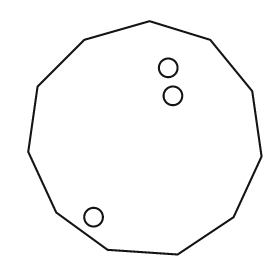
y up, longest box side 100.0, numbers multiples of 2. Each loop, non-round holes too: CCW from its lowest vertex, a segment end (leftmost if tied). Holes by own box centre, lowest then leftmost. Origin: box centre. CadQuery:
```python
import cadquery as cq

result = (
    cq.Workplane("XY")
    .moveTo(14.0, -50.0)
    .lineTo(38.0, -34.0)
    .lineTo(50.0, -8.0)
    .lineTo(46.0, 20.0)
    .lineTo(28.0, 42.0)
    .lineTo(2.0, 50.0)
    .lineTo(-26.0, 42.0)
    .lineTo(-46.0, 22.0)
    .lineTo(-50.0, -6.0)
    .lineTo(-38.0, -32.0)
    .lineTo(-16.0, -48.0)
    .close()
    .moveTo(-22.0, -34.0)
    .circle(4.0)
    .moveTo(12.0, 18.0)
    .circle(4.0)
    .moveTo(10.0, 30.0)
    .circle(4.0)
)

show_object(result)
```